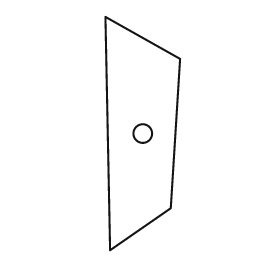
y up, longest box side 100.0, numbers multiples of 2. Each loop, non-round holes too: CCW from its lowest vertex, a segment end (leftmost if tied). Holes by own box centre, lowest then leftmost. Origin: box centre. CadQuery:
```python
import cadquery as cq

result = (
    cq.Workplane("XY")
    .moveTo(-14.0, -50.0)
    .lineTo(12.0, -32.0)
    .lineTo(16.0, 32.0)
    .lineTo(-16.0, 50.0)
    .close()
    .moveTo(0.0, 0.0)
    .circle(4.0)
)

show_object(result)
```